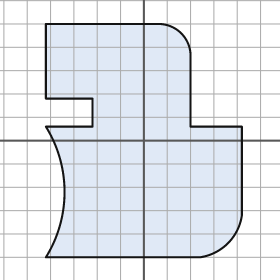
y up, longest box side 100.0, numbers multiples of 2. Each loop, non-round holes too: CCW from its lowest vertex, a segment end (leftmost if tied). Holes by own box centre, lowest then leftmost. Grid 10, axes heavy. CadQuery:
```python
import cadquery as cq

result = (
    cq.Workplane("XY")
    .moveTo(-42.0, -50.0)
    .lineTo(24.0, -50.0)
    .threePointArc((36.0, -44.0), (42.0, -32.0))
    .lineTo(42.0, 6.0)
    .lineTo(20.0, 6.0)
    .lineTo(20.0, 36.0)
    .threePointArc((16.0, 46.0), (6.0, 50.0))
    .lineTo(-42.0, 50.0)
    .lineTo(-42.0, 18.0)
    .lineTo(-22.0, 18.0)
    .lineTo(-22.0, 6.0)
    .lineTo(-42.0, 6.0)
    .threePointArc((-34.0, -22.0), (-42.0, -50.0))
    .close()
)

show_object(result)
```